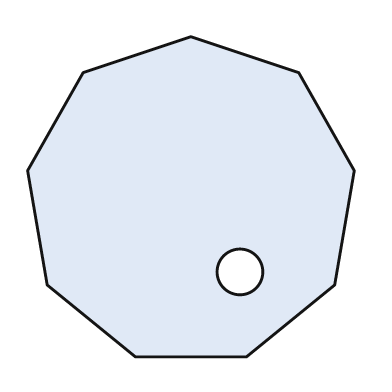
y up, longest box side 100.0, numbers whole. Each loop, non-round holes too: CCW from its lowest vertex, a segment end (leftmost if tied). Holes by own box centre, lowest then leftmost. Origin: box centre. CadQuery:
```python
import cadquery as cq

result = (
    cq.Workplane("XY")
    .moveTo(-17.0, -49.0)
    .lineTo(17.0, -49.0)
    .lineTo(44.0, -27.0)
    .lineTo(50.0, 8.0)
    .lineTo(33.0, 38.0)
    .lineTo(0.0, 49.0)
    .lineTo(-33.0, 38.0)
    .lineTo(-50.0, 8.0)
    .lineTo(-44.0, -27.0)
    .close()
    .moveTo(15.0, -23.0)
    .circle(7.0)
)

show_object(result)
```